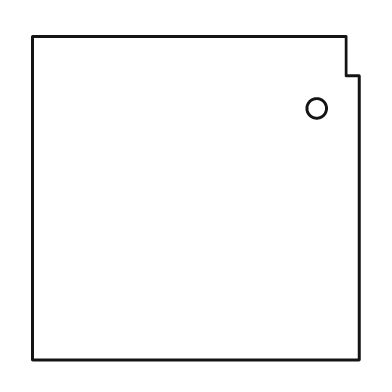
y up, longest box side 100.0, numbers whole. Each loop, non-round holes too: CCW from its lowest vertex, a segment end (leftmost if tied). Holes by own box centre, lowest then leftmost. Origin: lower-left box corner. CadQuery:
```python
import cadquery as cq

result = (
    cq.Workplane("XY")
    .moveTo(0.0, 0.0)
    .lineTo(100.0, 0.0)
    .lineTo(100.0, 87.0)
    .lineTo(96.0, 87.0)
    .lineTo(96.0, 99.0)
    .lineTo(0.0, 99.0)
    .close()
    .moveTo(87.0, 77.0)
    .circle(3.0)
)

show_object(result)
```